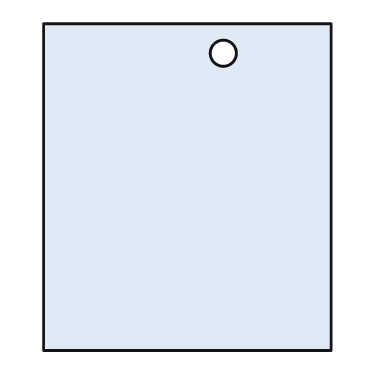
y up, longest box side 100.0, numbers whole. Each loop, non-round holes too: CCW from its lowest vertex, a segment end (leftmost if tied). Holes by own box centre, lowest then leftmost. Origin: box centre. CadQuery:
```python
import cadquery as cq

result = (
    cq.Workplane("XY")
    .moveTo(-44.0, -50.0)
    .lineTo(44.0, -50.0)
    .lineTo(44.0, 50.0)
    .lineTo(-44.0, 50.0)
    .close()
    .moveTo(11.0, 41.0)
    .circle(4.0)
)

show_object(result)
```